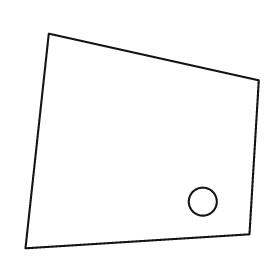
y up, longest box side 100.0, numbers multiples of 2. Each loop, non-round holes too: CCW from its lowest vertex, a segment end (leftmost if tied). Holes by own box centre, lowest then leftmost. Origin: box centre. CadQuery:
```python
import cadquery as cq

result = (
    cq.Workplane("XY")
    .moveTo(-50.0, -46.0)
    .lineTo(46.0, -40.0)
    .lineTo(50.0, 26.0)
    .lineTo(-40.0, 46.0)
    .close()
    .moveTo(26.0, -26.0)
    .circle(6.0)
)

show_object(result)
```